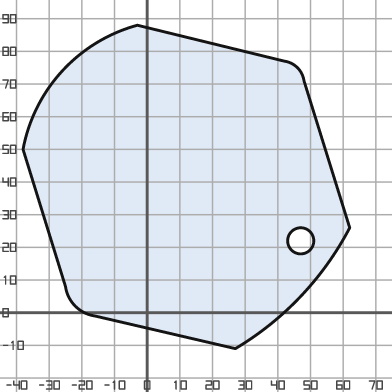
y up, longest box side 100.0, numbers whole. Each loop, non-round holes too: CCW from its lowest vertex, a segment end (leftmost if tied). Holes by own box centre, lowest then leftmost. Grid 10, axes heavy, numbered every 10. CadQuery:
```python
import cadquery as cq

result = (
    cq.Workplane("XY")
    .moveTo(27.0, -11.0)
    .threePointArc((47.0, 5.0), (62.0, 26.0))
    .lineTo(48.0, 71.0)
    .threePointArc((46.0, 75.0), (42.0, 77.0))
    .lineTo(-3.0, 88.0)
    .threePointArc((-26.0, 74.0), (-38.0, 50.0))
    .lineTo(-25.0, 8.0)
    .threePointArc((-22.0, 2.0), (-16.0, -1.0))
    .close()
    .moveTo(47.0, 22.0)
    .circle(4.0)
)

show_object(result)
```